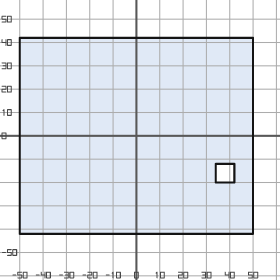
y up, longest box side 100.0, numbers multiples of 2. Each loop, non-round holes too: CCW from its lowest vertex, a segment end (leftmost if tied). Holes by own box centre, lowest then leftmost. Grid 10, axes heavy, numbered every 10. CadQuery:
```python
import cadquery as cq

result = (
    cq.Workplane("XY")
    .moveTo(-50.0, -42.0)
    .lineTo(50.0, -42.0)
    .lineTo(50.0, 42.0)
    .lineTo(-50.0, 42.0)
    .close()
    .moveTo(34.0, -20.0)
    .lineTo(42.0, -20.0)
    .lineTo(42.0, -12.0)
    .lineTo(34.0, -12.0)
    .close()
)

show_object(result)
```